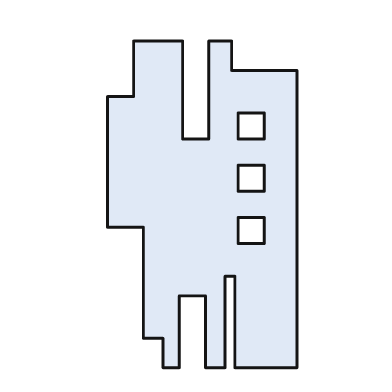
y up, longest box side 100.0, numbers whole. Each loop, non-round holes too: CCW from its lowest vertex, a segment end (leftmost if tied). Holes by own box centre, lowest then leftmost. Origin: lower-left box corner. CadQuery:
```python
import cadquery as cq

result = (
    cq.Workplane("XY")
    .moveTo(17.0, 0.0)
    .lineTo(22.0, 0.0)
    .lineTo(22.0, 22.0)
    .lineTo(30.0, 22.0)
    .lineTo(30.0, 0.0)
    .lineTo(36.0, 0.0)
    .lineTo(36.0, 28.0)
    .lineTo(39.0, 28.0)
    .lineTo(39.0, 0.0)
    .lineTo(58.0, 0.0)
    .lineTo(58.0, 91.0)
    .lineTo(38.0, 91.0)
    .lineTo(38.0, 100.0)
    .lineTo(31.0, 100.0)
    .lineTo(31.0, 70.0)
    .lineTo(23.0, 70.0)
    .lineTo(23.0, 100.0)
    .lineTo(8.0, 100.0)
    .lineTo(8.0, 83.0)
    .lineTo(0.0, 83.0)
    .lineTo(0.0, 43.0)
    .lineTo(11.0, 43.0)
    .lineTo(11.0, 9.0)
    .lineTo(17.0, 9.0)
    .close()
    .moveTo(40.0, 38.0)
    .lineTo(48.0, 38.0)
    .lineTo(48.0, 46.0)
    .lineTo(40.0, 46.0)
    .close()
    .moveTo(40.0, 54.0)
    .lineTo(48.0, 54.0)
    .lineTo(48.0, 62.0)
    .lineTo(40.0, 62.0)
    .close()
    .moveTo(40.0, 70.0)
    .lineTo(48.0, 70.0)
    .lineTo(48.0, 78.0)
    .lineTo(40.0, 78.0)
    .close()
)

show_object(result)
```